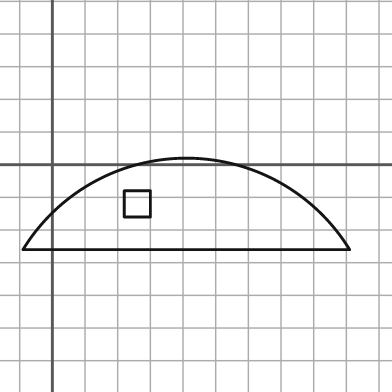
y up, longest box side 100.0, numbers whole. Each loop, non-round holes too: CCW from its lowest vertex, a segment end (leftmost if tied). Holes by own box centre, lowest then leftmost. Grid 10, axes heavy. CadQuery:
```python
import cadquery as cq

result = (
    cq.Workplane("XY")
    .moveTo(-9.0, -26.0)
    .lineTo(91.0, -26.0)
    .threePointArc((41.0, 2.0), (-9.0, -26.0))
    .close()
    .moveTo(22.0, -16.0)
    .lineTo(30.0, -16.0)
    .lineTo(30.0, -8.0)
    .lineTo(22.0, -8.0)
    .close()
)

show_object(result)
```